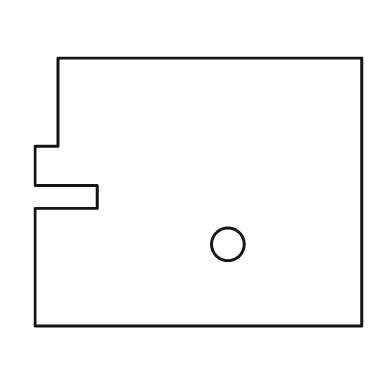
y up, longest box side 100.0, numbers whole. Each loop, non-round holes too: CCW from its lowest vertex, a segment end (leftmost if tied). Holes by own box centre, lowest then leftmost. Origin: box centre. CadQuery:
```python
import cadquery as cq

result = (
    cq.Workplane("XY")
    .moveTo(-50.0, -41.0)
    .lineTo(50.0, -41.0)
    .lineTo(50.0, 41.0)
    .lineTo(-43.0, 41.0)
    .lineTo(-43.0, 14.0)
    .lineTo(-50.0, 14.0)
    .lineTo(-50.0, 2.0)
    .lineTo(-31.0, 2.0)
    .lineTo(-31.0, -5.0)
    .lineTo(-50.0, -5.0)
    .close()
    .moveTo(9.0, -16.0)
    .circle(5.0)
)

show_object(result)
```